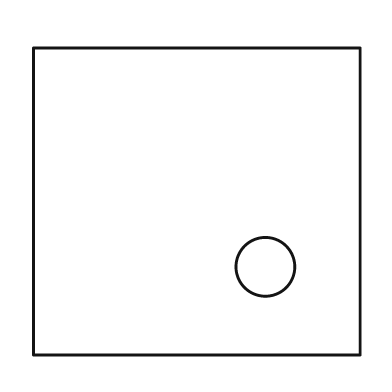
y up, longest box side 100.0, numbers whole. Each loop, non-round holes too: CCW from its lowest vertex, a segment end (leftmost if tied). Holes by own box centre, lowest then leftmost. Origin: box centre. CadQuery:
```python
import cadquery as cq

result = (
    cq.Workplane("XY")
    .moveTo(-50.0, -47.0)
    .lineTo(50.0, -47.0)
    .lineTo(50.0, 47.0)
    .lineTo(-50.0, 47.0)
    .close()
    .moveTo(21.0, -20.0)
    .circle(9.0)
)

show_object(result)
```